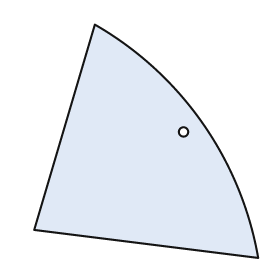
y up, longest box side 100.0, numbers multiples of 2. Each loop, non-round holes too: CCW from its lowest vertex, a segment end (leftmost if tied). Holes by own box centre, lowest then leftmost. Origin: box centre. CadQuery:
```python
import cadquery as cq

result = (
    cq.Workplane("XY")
    .moveTo(48.0, -50.0)
    .threePointArc((24.0, 8.0), (-22.0, 50.0))
    .lineTo(-48.0, -38.0)
    .close()
    .moveTo(16.0, 4.0)
    .circle(2.0)
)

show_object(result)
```